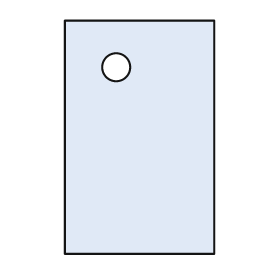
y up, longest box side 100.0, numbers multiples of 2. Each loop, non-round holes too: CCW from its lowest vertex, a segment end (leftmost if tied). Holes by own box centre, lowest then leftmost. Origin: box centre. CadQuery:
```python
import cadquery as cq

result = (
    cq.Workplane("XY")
    .moveTo(-32.0, -50.0)
    .lineTo(32.0, -50.0)
    .lineTo(32.0, 50.0)
    .lineTo(-32.0, 50.0)
    .close()
    .moveTo(-10.0, 30.0)
    .circle(6.0)
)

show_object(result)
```